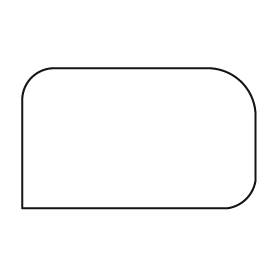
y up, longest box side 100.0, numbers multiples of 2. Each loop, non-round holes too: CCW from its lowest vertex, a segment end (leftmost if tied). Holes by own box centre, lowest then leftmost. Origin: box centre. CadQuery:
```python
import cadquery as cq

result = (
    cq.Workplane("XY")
    .moveTo(-50.0, -30.0)
    .lineTo(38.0, -30.0)
    .threePointArc((46.0, -26.0), (50.0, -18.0))
    .lineTo(50.0, 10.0)
    .threePointArc((44.0, 24.0), (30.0, 30.0))
    .lineTo(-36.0, 30.0)
    .threePointArc((-46.0, 26.0), (-50.0, 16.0))
    .close()
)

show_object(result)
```